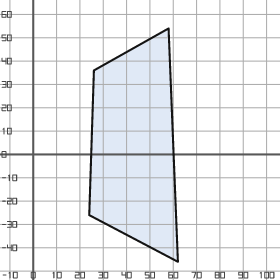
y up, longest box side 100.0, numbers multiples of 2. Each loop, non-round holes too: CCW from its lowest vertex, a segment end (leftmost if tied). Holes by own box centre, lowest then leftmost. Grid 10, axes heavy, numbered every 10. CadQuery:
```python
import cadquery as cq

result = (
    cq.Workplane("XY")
    .moveTo(62.0, -46.0)
    .lineTo(58.0, 54.0)
    .lineTo(26.0, 36.0)
    .lineTo(24.0, -26.0)
    .close()
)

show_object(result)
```